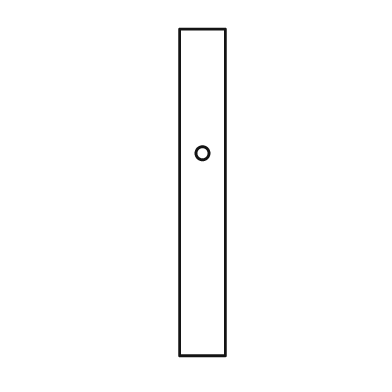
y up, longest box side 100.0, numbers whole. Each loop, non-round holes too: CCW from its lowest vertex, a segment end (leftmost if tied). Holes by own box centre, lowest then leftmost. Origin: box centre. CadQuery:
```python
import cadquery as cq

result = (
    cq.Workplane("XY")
    .moveTo(-7.0, -50.0)
    .lineTo(7.0, -50.0)
    .lineTo(7.0, 50.0)
    .lineTo(-7.0, 50.0)
    .close()
    .moveTo(0.0, 12.0)
    .circle(2.0)
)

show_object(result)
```